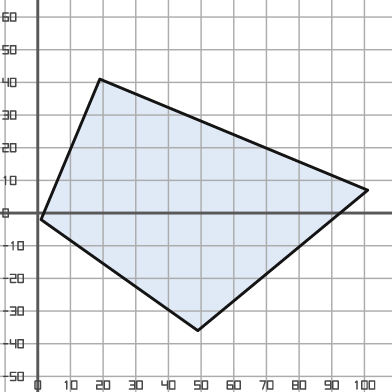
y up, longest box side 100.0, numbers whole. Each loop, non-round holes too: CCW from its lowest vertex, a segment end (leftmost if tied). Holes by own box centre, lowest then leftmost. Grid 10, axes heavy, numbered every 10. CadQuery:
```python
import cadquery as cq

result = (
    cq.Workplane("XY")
    .moveTo(49.0, -36.0)
    .lineTo(101.0, 7.0)
    .lineTo(19.0, 41.0)
    .lineTo(1.0, -2.0)
    .close()
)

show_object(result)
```